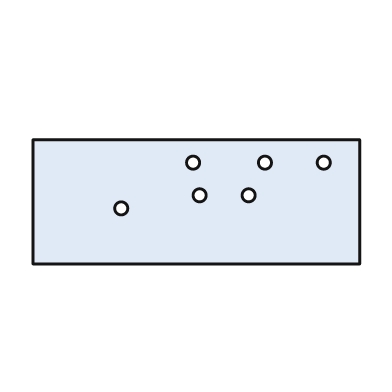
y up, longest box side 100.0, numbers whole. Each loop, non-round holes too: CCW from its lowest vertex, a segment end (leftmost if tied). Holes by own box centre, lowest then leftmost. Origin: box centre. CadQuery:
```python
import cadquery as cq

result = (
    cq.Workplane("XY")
    .moveTo(-50.0, -19.0)
    .lineTo(50.0, -19.0)
    .lineTo(50.0, 19.0)
    .lineTo(-50.0, 19.0)
    .close()
    .moveTo(-23.0, -2.0)
    .circle(2.0)
    .moveTo(1.0, 2.0)
    .circle(2.0)
    .moveTo(16.0, 2.0)
    .circle(2.0)
    .moveTo(-1.0, 12.0)
    .circle(2.0)
    .moveTo(21.0, 12.0)
    .circle(2.0)
    .moveTo(39.0, 12.0)
    .circle(2.0)
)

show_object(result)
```